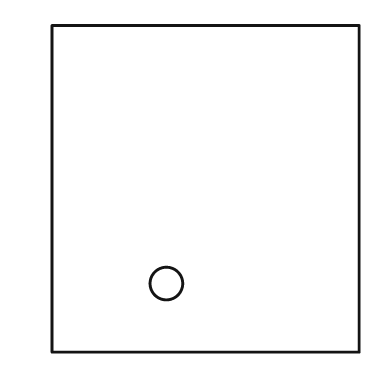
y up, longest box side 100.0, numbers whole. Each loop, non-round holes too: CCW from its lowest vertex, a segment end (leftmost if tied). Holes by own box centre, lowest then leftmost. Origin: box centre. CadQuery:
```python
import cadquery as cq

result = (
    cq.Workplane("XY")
    .moveTo(-47.0, -50.0)
    .lineTo(47.0, -50.0)
    .lineTo(47.0, 50.0)
    .lineTo(-47.0, 50.0)
    .close()
    .moveTo(-12.0, -29.0)
    .circle(5.0)
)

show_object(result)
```